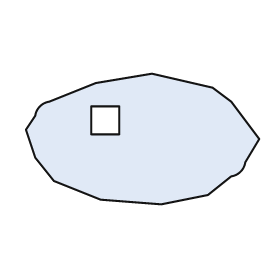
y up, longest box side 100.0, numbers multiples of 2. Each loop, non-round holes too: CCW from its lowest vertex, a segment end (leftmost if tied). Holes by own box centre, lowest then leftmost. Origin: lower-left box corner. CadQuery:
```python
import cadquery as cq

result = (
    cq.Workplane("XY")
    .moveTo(58.0, 0.0)
    .lineTo(78.0, 4.0)
    .lineTo(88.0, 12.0)
    .threePointArc((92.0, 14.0), (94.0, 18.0))
    .lineTo(100.0, 28.0)
    .lineTo(88.0, 44.0)
    .lineTo(80.0, 50.0)
    .lineTo(54.0, 56.0)
    .lineTo(30.0, 52.0)
    .lineTo(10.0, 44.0)
    .threePointArc((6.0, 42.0), (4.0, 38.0))
    .lineTo(0.0, 32.0)
    .lineTo(4.0, 20.0)
    .lineTo(12.0, 10.0)
    .lineTo(32.0, 2.0)
    .close()
    .moveTo(28.0, 30.0)
    .lineTo(40.0, 30.0)
    .lineTo(40.0, 42.0)
    .lineTo(28.0, 42.0)
    .close()
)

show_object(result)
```